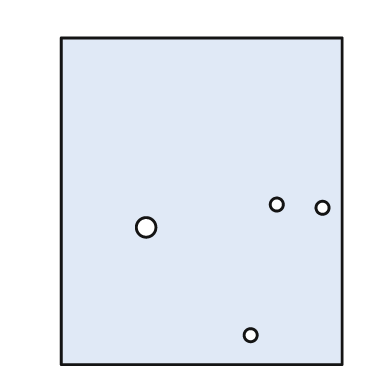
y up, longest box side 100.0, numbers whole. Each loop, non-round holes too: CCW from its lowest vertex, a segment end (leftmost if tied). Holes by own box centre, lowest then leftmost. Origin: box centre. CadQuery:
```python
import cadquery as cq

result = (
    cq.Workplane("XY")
    .moveTo(-43.0, -50.0)
    .lineTo(43.0, -50.0)
    .lineTo(43.0, 50.0)
    .lineTo(-43.0, 50.0)
    .close()
    .moveTo(15.0, -41.0)
    .circle(2.0)
    .moveTo(-17.0, -8.0)
    .circle(3.0)
    .moveTo(37.0, -2.0)
    .circle(2.0)
    .moveTo(23.0, -1.0)
    .circle(2.0)
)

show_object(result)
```